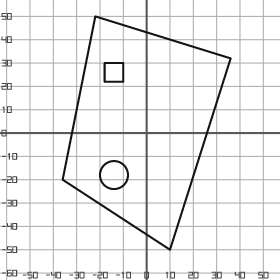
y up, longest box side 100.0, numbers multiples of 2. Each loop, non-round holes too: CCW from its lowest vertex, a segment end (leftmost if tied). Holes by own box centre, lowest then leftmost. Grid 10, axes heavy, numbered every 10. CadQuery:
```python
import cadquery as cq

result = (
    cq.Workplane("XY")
    .moveTo(10.0, -50.0)
    .lineTo(36.0, 32.0)
    .lineTo(-22.0, 50.0)
    .lineTo(-36.0, -20.0)
    .close()
    .moveTo(-14.0, -18.0)
    .circle(6.0)
    .moveTo(-18.0, 22.0)
    .lineTo(-10.0, 22.0)
    .lineTo(-10.0, 30.0)
    .lineTo(-18.0, 30.0)
    .close()
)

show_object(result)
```